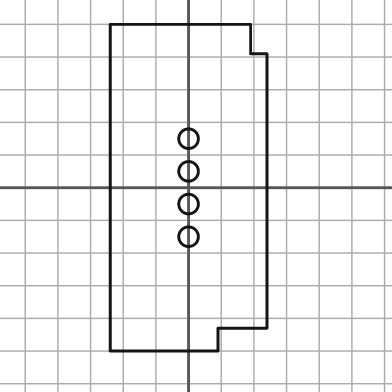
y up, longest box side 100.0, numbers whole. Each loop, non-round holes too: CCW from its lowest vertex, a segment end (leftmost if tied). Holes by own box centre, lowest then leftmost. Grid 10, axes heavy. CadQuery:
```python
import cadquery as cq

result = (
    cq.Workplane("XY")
    .moveTo(-24.0, -50.0)
    .lineTo(9.0, -50.0)
    .lineTo(9.0, -43.0)
    .lineTo(24.0, -43.0)
    .lineTo(24.0, 41.0)
    .lineTo(19.0, 41.0)
    .lineTo(19.0, 50.0)
    .lineTo(-24.0, 50.0)
    .close()
    .moveTo(0.0, -15.0)
    .circle(3.0)
    .moveTo(0.0, -5.0)
    .circle(3.0)
    .moveTo(0.0, 5.0)
    .circle(3.0)
    .moveTo(0.0, 15.0)
    .circle(3.0)
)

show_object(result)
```